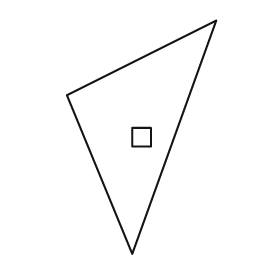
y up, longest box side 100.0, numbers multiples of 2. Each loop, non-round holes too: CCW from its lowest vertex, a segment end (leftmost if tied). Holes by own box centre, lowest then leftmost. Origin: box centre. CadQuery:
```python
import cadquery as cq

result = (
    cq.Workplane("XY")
    .moveTo(-4.0, -50.0)
    .lineTo(32.0, 50.0)
    .lineTo(-32.0, 18.0)
    .close()
    .moveTo(-4.0, -4.0)
    .lineTo(4.0, -4.0)
    .lineTo(4.0, 4.0)
    .lineTo(-4.0, 4.0)
    .close()
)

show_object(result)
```